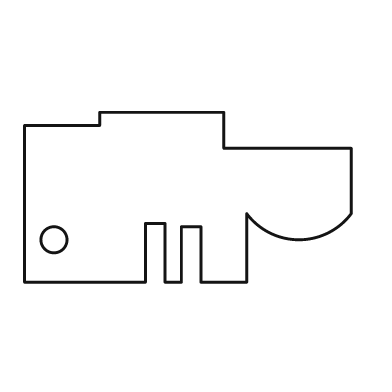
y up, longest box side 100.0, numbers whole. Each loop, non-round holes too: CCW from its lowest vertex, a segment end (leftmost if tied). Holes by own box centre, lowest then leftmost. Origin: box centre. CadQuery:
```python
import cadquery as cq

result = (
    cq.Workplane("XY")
    .moveTo(-50.0, -26.0)
    .lineTo(-13.0, -26.0)
    .lineTo(-13.0, -8.0)
    .lineTo(-7.0, -8.0)
    .lineTo(-7.0, -26.0)
    .lineTo(-2.0, -26.0)
    .lineTo(-2.0, -9.0)
    .lineTo(4.0, -9.0)
    .lineTo(4.0, -26.0)
    .lineTo(18.0, -26.0)
    .lineTo(18.0, -5.0)
    .threePointArc((34.0, -13.0), (50.0, -5.0))
    .lineTo(50.0, 15.0)
    .lineTo(11.0, 15.0)
    .lineTo(11.0, 26.0)
    .lineTo(-27.0, 26.0)
    .lineTo(-27.0, 22.0)
    .lineTo(-50.0, 22.0)
    .close()
    .moveTo(-41.0, -13.0)
    .circle(4.0)
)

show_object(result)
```